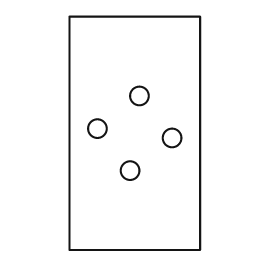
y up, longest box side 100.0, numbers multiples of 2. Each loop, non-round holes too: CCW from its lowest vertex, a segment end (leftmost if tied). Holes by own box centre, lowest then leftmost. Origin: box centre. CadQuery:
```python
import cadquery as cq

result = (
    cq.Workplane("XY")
    .moveTo(-28.0, -50.0)
    .lineTo(28.0, -50.0)
    .lineTo(28.0, 50.0)
    .lineTo(-28.0, 50.0)
    .close()
    .moveTo(-2.0, -16.0)
    .circle(4.0)
    .moveTo(16.0, -2.0)
    .circle(4.0)
    .moveTo(-16.0, 2.0)
    .circle(4.0)
    .moveTo(2.0, 16.0)
    .circle(4.0)
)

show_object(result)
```